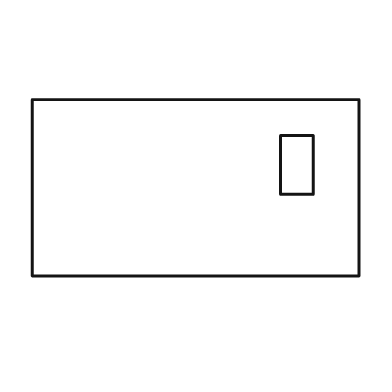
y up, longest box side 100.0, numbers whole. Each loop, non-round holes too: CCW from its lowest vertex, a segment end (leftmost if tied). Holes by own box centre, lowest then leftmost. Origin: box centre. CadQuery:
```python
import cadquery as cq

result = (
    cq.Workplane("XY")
    .moveTo(-50.0, -27.0)
    .lineTo(50.0, -27.0)
    .lineTo(50.0, 27.0)
    .lineTo(-50.0, 27.0)
    .close()
    .moveTo(26.0, -2.0)
    .lineTo(36.0, -2.0)
    .lineTo(36.0, 16.0)
    .lineTo(26.0, 16.0)
    .close()
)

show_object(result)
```